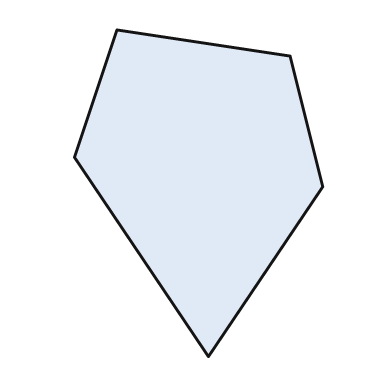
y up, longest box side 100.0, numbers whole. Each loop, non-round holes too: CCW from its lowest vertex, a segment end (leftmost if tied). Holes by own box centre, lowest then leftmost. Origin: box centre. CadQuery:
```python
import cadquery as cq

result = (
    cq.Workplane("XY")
    .moveTo(3.0, -50.0)
    .lineTo(38.0, 2.0)
    .lineTo(28.0, 42.0)
    .lineTo(-25.0, 50.0)
    .lineTo(-38.0, 11.0)
    .close()
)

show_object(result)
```